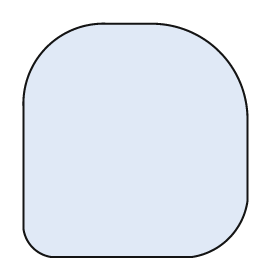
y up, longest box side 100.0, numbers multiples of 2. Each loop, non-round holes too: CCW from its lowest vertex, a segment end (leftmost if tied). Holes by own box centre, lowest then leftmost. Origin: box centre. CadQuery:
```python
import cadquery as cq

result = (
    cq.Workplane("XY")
    .moveTo(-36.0, -50.0)
    .lineTo(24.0, -50.0)
    .threePointArc((40.0, -42.0), (48.0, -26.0))
    .lineTo(48.0, 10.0)
    .threePointArc((36.0, 38.0), (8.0, 50.0))
    .lineTo(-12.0, 50.0)
    .threePointArc((-38.0, 40.0), (-48.0, 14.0))
    .lineTo(-48.0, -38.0)
    .threePointArc((-44.0, -46.0), (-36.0, -50.0))
    .close()
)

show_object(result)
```